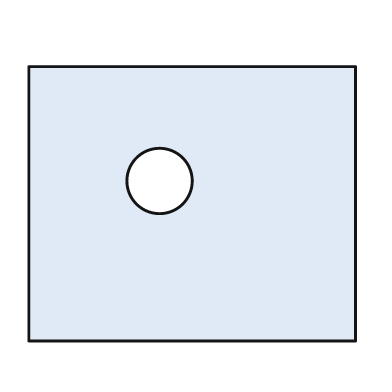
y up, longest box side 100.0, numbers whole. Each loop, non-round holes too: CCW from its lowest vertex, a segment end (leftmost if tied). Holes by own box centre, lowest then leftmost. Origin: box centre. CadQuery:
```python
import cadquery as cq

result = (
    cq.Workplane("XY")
    .moveTo(-50.0, -42.0)
    .lineTo(50.0, -42.0)
    .lineTo(50.0, 42.0)
    .lineTo(-50.0, 42.0)
    .close()
    .moveTo(-10.0, 7.0)
    .circle(10.0)
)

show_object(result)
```